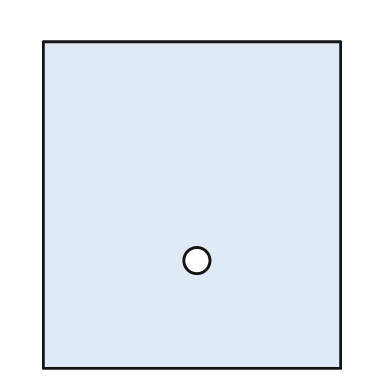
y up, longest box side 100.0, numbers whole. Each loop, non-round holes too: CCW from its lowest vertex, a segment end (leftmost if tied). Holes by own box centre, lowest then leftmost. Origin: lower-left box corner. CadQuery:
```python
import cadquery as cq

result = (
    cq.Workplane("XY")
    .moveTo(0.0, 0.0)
    .lineTo(91.0, 0.0)
    .lineTo(91.0, 100.0)
    .lineTo(0.0, 100.0)
    .close()
    .moveTo(47.0, 33.0)
    .circle(4.0)
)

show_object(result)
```